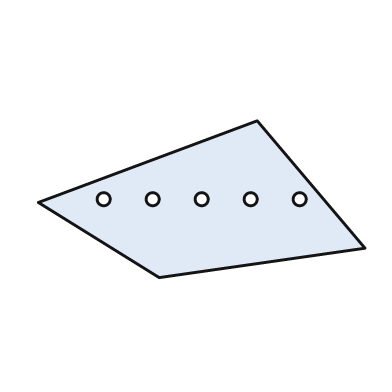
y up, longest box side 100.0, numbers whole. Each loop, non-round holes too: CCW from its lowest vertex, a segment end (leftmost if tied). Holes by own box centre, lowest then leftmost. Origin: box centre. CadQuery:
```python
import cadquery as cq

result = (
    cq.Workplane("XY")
    .moveTo(-13.0, -24.0)
    .lineTo(50.0, -15.0)
    .lineTo(17.0, 24.0)
    .lineTo(-50.0, -1.0)
    .close()
    .moveTo(-30.0, 0.0)
    .circle(2.0)
    .moveTo(-15.0, 0.0)
    .circle(2.0)
    .moveTo(0.0, 0.0)
    .circle(2.0)
    .moveTo(15.0, 0.0)
    .circle(2.0)
    .moveTo(30.0, 0.0)
    .circle(2.0)
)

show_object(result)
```